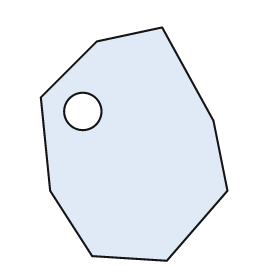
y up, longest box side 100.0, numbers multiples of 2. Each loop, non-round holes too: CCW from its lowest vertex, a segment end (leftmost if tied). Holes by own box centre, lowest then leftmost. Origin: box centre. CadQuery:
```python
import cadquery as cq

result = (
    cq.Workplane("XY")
    .moveTo(14.0, -50.0)
    .lineTo(40.0, -20.0)
    .lineTo(34.0, 10.0)
    .lineTo(12.0, 50.0)
    .lineTo(-16.0, 44.0)
    .lineTo(-40.0, 20.0)
    .lineTo(-36.0, -20.0)
    .lineTo(-18.0, -48.0)
    .close()
    .moveTo(-22.0, 14.0)
    .circle(8.0)
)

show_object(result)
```